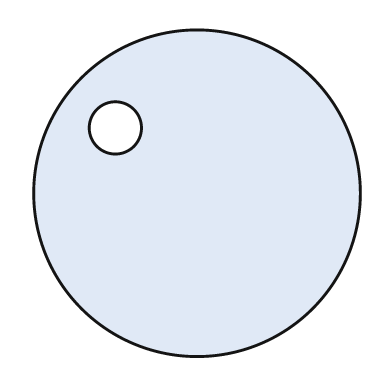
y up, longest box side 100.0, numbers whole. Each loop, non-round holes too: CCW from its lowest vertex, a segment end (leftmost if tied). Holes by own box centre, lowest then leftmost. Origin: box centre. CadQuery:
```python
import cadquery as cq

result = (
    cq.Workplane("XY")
    .moveTo(0.0, 0.0)
    .circle(50.0)
    .moveTo(-25.0, 20.0)
    .circle(8.0)
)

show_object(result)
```